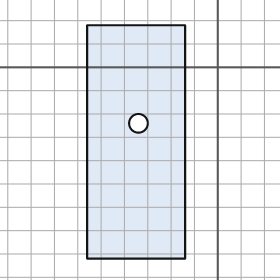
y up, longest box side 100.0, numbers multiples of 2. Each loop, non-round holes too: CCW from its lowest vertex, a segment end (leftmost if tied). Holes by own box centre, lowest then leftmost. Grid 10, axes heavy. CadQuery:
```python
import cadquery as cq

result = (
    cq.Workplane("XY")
    .moveTo(-56.0, -82.0)
    .lineTo(-14.0, -82.0)
    .lineTo(-14.0, 18.0)
    .lineTo(-56.0, 18.0)
    .close()
    .moveTo(-34.0, -24.0)
    .circle(4.0)
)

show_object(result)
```